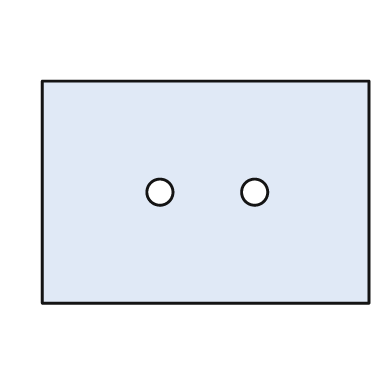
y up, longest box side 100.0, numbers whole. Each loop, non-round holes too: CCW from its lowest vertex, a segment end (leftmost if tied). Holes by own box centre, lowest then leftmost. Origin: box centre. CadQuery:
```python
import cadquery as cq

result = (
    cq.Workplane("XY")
    .moveTo(-50.0, -34.0)
    .lineTo(50.0, -34.0)
    .lineTo(50.0, 34.0)
    .lineTo(-50.0, 34.0)
    .close()
    .moveTo(-14.0, 0.0)
    .circle(4.0)
    .moveTo(15.0, 0.0)
    .circle(4.0)
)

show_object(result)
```